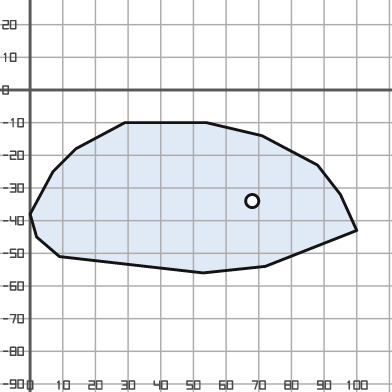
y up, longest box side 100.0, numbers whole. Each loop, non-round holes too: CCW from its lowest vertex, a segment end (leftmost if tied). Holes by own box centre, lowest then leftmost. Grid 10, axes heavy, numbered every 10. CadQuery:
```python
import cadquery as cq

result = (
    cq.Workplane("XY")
    .moveTo(53.0, -56.0)
    .lineTo(72.0, -54.0)
    .lineTo(100.0, -43.0)
    .lineTo(95.0, -32.0)
    .lineTo(88.0, -23.0)
    .lineTo(71.0, -14.0)
    .lineTo(54.0, -10.0)
    .lineTo(29.0, -10.0)
    .lineTo(14.0, -18.0)
    .lineTo(7.0, -25.0)
    .lineTo(0.0, -38.0)
    .lineTo(2.0, -45.0)
    .lineTo(9.0, -51.0)
    .close()
    .moveTo(68.0, -34.0)
    .circle(2.0)
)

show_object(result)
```